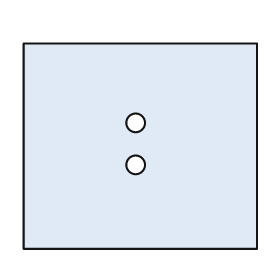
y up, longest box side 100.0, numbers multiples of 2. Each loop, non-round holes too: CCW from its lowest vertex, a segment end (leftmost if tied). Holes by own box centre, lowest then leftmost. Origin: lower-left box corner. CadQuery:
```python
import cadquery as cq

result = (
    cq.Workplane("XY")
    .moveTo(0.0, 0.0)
    .lineTo(100.0, 0.0)
    .lineTo(100.0, 88.0)
    .lineTo(0.0, 88.0)
    .close()
    .moveTo(48.0, 36.0)
    .circle(4.0)
    .moveTo(48.0, 54.0)
    .circle(4.0)
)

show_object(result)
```